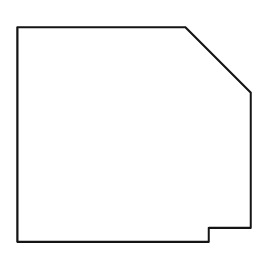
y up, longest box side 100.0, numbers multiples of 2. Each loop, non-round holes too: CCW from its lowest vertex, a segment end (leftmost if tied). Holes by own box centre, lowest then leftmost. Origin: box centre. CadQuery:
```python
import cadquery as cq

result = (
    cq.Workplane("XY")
    .moveTo(-50.0, -46.0)
    .lineTo(32.0, -46.0)
    .lineTo(32.0, -40.0)
    .lineTo(50.0, -40.0)
    .lineTo(50.0, 18.0)
    .lineTo(22.0, 46.0)
    .lineTo(-50.0, 46.0)
    .close()
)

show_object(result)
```